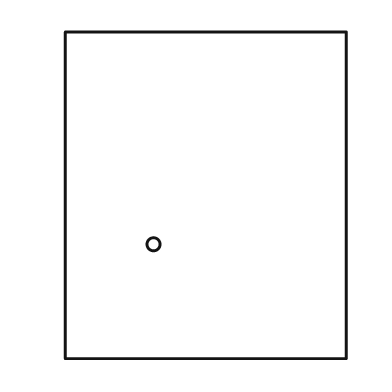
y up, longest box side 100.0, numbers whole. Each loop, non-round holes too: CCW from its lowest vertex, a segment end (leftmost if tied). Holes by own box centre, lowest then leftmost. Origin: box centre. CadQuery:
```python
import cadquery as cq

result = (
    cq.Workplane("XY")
    .moveTo(-43.0, -50.0)
    .lineTo(43.0, -50.0)
    .lineTo(43.0, 50.0)
    .lineTo(-43.0, 50.0)
    .close()
    .moveTo(-16.0, -15.0)
    .circle(2.0)
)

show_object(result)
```